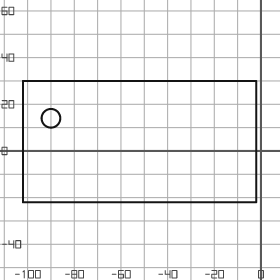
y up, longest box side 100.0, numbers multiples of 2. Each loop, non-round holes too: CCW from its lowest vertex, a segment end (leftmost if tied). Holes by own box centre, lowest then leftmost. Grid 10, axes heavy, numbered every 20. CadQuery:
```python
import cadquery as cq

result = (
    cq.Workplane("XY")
    .moveTo(-102.0, -22.0)
    .lineTo(-2.0, -22.0)
    .lineTo(-2.0, 30.0)
    .lineTo(-102.0, 30.0)
    .close()
    .moveTo(-90.0, 14.0)
    .circle(4.0)
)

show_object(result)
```